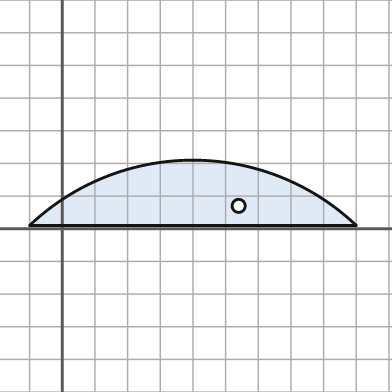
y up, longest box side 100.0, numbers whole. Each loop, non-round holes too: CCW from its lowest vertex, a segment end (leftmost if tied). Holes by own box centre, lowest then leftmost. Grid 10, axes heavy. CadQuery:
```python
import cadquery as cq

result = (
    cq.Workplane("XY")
    .moveTo(-10.0, 1.0)
    .lineTo(90.0, 1.0)
    .threePointArc((40.0, 21.0), (-10.0, 1.0))
    .close()
    .moveTo(54.0, 7.0)
    .circle(2.0)
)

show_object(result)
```